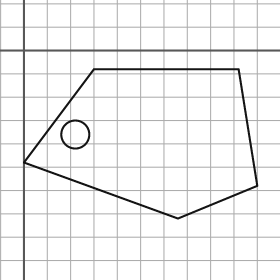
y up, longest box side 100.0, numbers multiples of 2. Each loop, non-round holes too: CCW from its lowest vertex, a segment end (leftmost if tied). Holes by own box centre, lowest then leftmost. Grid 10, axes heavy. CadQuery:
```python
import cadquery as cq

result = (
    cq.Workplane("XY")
    .moveTo(66.0, -72.0)
    .lineTo(100.0, -58.0)
    .lineTo(92.0, -8.0)
    .lineTo(30.0, -8.0)
    .lineTo(0.0, -48.0)
    .close()
    .moveTo(22.0, -36.0)
    .circle(6.0)
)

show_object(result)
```